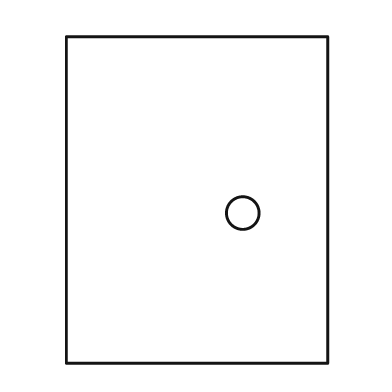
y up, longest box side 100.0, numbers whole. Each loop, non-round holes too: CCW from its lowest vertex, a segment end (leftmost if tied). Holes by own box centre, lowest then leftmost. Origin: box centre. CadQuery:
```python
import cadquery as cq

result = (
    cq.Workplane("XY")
    .moveTo(-40.0, -50.0)
    .lineTo(40.0, -50.0)
    .lineTo(40.0, 50.0)
    .lineTo(-40.0, 50.0)
    .close()
    .moveTo(14.0, -4.0)
    .circle(5.0)
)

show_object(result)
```